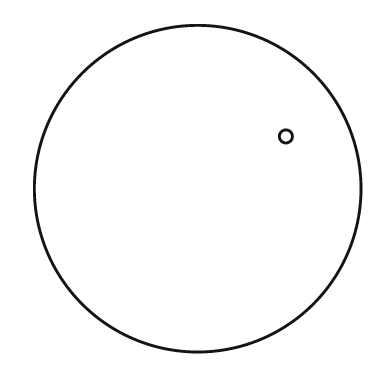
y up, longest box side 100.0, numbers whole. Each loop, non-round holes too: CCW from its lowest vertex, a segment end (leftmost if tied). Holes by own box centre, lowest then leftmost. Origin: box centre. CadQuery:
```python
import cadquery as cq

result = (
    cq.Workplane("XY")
    .moveTo(0.0, 0.0)
    .circle(50.0)
    .moveTo(27.0, 16.0)
    .circle(2.0)
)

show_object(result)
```